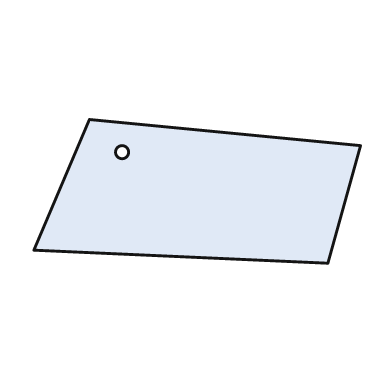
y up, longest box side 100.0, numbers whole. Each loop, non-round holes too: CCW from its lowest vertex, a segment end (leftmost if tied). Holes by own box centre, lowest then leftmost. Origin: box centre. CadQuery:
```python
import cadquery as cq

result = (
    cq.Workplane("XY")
    .moveTo(40.0, -22.0)
    .lineTo(50.0, 14.0)
    .lineTo(-33.0, 22.0)
    .lineTo(-50.0, -18.0)
    .close()
    .moveTo(-23.0, 12.0)
    .circle(2.0)
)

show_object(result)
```